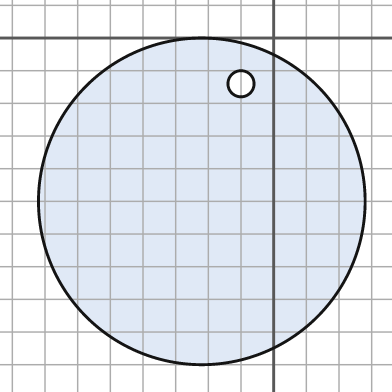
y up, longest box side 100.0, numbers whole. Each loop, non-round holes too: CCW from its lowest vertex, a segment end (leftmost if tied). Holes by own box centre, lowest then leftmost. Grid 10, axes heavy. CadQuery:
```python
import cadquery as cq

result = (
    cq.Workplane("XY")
    .moveTo(-22.0, -50.0)
    .circle(50.0)
    .moveTo(-10.0, -14.0)
    .circle(4.0)
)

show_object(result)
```